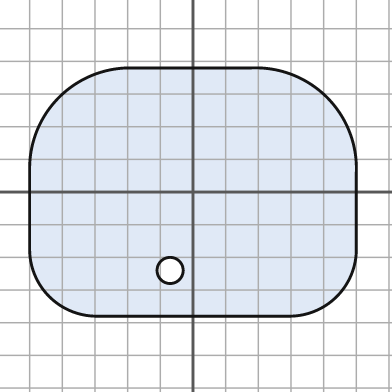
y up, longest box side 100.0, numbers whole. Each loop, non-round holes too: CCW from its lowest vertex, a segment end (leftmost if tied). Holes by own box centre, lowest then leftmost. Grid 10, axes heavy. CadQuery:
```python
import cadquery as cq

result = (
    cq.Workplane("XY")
    .moveTo(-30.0, -38.0)
    .lineTo(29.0, -38.0)
    .threePointArc((44.0, -32.0), (50.0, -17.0))
    .lineTo(50.0, 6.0)
    .threePointArc((41.0, 29.0), (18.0, 38.0))
    .lineTo(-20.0, 38.0)
    .threePointArc((-41.0, 29.0), (-50.0, 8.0))
    .lineTo(-50.0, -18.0)
    .threePointArc((-44.0, -32.0), (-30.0, -38.0))
    .close()
    .moveTo(-7.0, -24.0)
    .circle(4.0)
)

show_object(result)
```